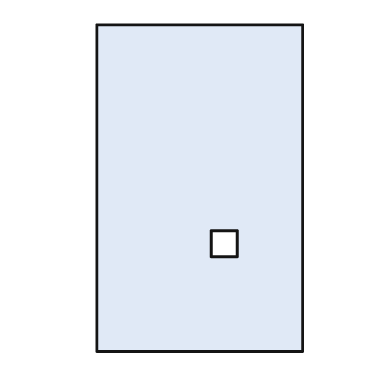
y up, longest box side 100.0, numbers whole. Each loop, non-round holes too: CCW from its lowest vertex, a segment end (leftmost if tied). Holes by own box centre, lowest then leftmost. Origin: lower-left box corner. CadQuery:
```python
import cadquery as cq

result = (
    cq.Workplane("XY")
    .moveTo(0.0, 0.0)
    .lineTo(63.0, 0.0)
    .lineTo(63.0, 100.0)
    .lineTo(0.0, 100.0)
    .close()
    .moveTo(35.0, 29.0)
    .lineTo(43.0, 29.0)
    .lineTo(43.0, 37.0)
    .lineTo(35.0, 37.0)
    .close()
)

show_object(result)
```